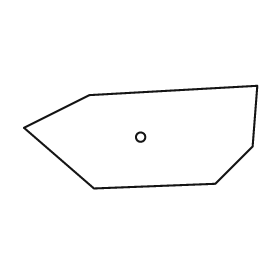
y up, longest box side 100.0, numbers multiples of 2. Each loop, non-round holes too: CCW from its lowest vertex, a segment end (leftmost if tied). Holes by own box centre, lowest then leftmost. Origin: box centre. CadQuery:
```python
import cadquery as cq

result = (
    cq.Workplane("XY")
    .moveTo(-20.0, -22.0)
    .lineTo(32.0, -20.0)
    .lineTo(48.0, -4.0)
    .lineTo(50.0, 22.0)
    .lineTo(-22.0, 18.0)
    .lineTo(-50.0, 4.0)
    .close()
    .moveTo(0.0, 0.0)
    .circle(2.0)
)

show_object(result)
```